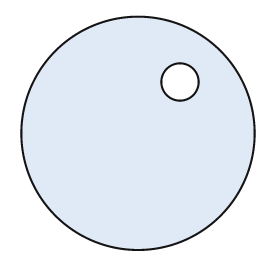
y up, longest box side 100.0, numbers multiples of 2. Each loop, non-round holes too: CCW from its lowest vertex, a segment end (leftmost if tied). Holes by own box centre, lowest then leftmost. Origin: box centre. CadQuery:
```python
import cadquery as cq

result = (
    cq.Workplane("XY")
    .moveTo(0.0, 0.0)
    .circle(50.0)
    .moveTo(18.0, 22.0)
    .circle(8.0)
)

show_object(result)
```